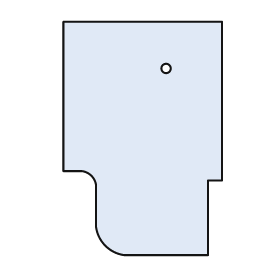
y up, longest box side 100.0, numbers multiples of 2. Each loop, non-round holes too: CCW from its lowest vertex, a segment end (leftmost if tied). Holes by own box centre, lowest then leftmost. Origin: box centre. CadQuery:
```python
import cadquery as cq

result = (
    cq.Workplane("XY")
    .moveTo(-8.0, -50.0)
    .lineTo(28.0, -50.0)
    .lineTo(28.0, -18.0)
    .lineTo(34.0, -18.0)
    .lineTo(34.0, 50.0)
    .lineTo(-34.0, 50.0)
    .lineTo(-34.0, -14.0)
    .lineTo(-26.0, -14.0)
    .threePointArc((-22.0, -16.0), (-20.0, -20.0))
    .lineTo(-20.0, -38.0)
    .threePointArc((-16.0, -46.0), (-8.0, -50.0))
    .close()
    .moveTo(10.0, 30.0)
    .circle(2.0)
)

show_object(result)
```